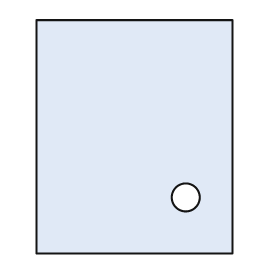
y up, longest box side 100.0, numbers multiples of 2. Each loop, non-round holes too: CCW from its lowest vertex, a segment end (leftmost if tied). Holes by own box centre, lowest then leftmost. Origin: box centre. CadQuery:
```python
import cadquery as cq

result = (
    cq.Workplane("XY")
    .moveTo(-42.0, -50.0)
    .lineTo(42.0, -50.0)
    .lineTo(42.0, 50.0)
    .lineTo(-42.0, 50.0)
    .close()
    .moveTo(22.0, -26.0)
    .circle(6.0)
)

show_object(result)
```